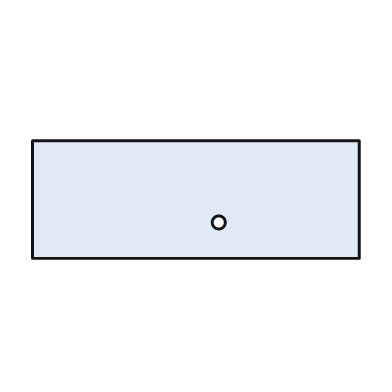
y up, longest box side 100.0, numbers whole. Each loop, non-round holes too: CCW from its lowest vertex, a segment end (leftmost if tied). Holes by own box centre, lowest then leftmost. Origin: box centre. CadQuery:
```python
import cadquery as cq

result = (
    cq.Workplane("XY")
    .moveTo(-50.0, -18.0)
    .lineTo(50.0, -18.0)
    .lineTo(50.0, 18.0)
    .lineTo(-50.0, 18.0)
    .close()
    .moveTo(7.0, -7.0)
    .circle(2.0)
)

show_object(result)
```